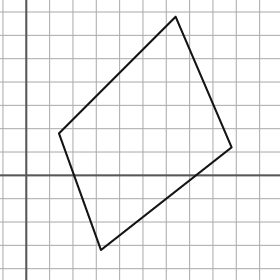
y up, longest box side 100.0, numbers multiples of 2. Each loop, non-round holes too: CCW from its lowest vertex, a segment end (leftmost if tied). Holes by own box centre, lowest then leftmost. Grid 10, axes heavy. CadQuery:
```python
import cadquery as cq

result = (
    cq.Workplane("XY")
    .moveTo(32.0, -32.0)
    .lineTo(88.0, 12.0)
    .lineTo(64.0, 68.0)
    .lineTo(14.0, 18.0)
    .close()
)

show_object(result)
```